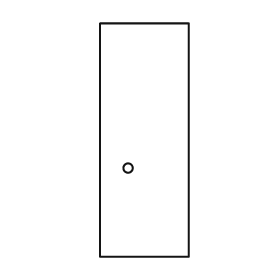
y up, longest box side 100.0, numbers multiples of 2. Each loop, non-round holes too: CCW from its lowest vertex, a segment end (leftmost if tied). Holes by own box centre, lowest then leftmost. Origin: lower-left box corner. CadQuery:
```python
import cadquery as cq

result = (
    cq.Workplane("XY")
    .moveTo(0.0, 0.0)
    .lineTo(38.0, 0.0)
    .lineTo(38.0, 100.0)
    .lineTo(0.0, 100.0)
    .close()
    .moveTo(12.0, 38.0)
    .circle(2.0)
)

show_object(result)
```